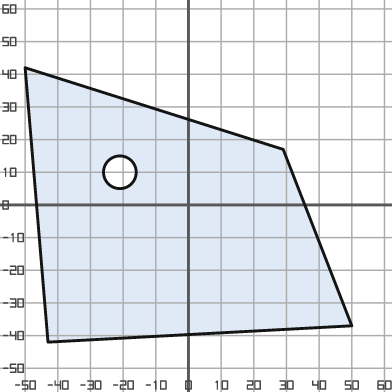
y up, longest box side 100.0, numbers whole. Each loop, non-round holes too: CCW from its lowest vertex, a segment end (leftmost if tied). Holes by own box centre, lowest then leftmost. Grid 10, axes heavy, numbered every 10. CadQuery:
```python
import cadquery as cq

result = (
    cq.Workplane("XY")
    .moveTo(-43.0, -42.0)
    .lineTo(50.0, -37.0)
    .lineTo(29.0, 17.0)
    .lineTo(-50.0, 42.0)
    .close()
    .moveTo(-21.0, 10.0)
    .circle(5.0)
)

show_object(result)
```